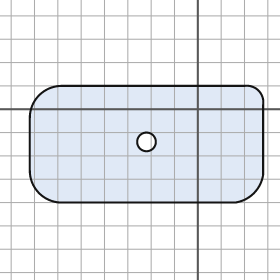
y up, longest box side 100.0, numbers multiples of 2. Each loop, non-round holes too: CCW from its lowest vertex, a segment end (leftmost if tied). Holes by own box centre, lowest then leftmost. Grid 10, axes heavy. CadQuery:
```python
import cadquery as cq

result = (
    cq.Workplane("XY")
    .moveTo(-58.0, -40.0)
    .lineTo(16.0, -40.0)
    .threePointArc((24.0, -36.0), (28.0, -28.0))
    .lineTo(28.0, 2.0)
    .threePointArc((26.0, 8.0), (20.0, 10.0))
    .lineTo(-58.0, 10.0)
    .threePointArc((-68.0, 6.0), (-72.0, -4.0))
    .lineTo(-72.0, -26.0)
    .threePointArc((-68.0, -36.0), (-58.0, -40.0))
    .close()
    .moveTo(-22.0, -14.0)
    .circle(4.0)
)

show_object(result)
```